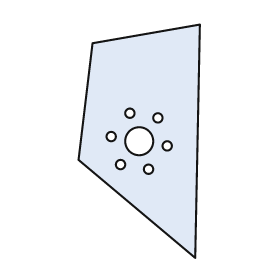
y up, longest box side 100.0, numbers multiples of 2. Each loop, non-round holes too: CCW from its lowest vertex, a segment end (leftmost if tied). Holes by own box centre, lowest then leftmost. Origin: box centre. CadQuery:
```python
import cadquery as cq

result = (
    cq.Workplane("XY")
    .moveTo(24.0, -50.0)
    .lineTo(26.0, 50.0)
    .lineTo(-20.0, 42.0)
    .lineTo(-26.0, -8.0)
    .close()
    .moveTo(4.0, -12.0)
    .circle(2.0)
    .moveTo(-8.0, -10.0)
    .circle(2.0)
    .moveTo(12.0, -2.0)
    .circle(2.0)
    .moveTo(0.0, 0.0)
    .circle(6.0)
    .moveTo(-12.0, 2.0)
    .circle(2.0)
    .moveTo(8.0, 10.0)
    .circle(2.0)
    .moveTo(-4.0, 12.0)
    .circle(2.0)
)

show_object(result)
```